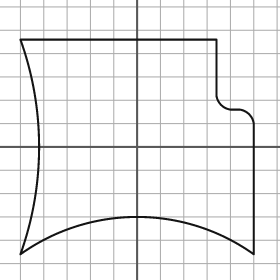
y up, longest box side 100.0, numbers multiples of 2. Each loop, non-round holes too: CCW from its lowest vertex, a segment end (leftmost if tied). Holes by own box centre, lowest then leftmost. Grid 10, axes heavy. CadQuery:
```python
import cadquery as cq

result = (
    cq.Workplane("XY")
    .moveTo(-50.0, -46.0)
    .threePointArc((0.0, -30.0), (50.0, -46.0))
    .lineTo(50.0, 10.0)
    .threePointArc((48.0, 14.0), (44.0, 16.0))
    .lineTo(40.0, 16.0)
    .threePointArc((36.0, 18.0), (34.0, 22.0))
    .lineTo(34.0, 46.0)
    .lineTo(-50.0, 46.0)
    .threePointArc((-42.0, 0.0), (-50.0, -46.0))
    .close()
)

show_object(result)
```